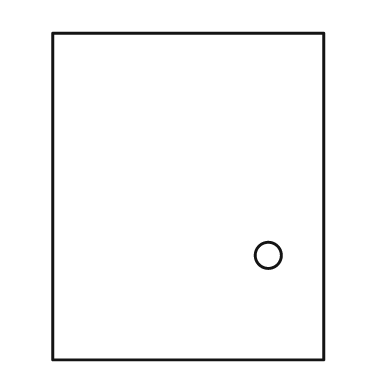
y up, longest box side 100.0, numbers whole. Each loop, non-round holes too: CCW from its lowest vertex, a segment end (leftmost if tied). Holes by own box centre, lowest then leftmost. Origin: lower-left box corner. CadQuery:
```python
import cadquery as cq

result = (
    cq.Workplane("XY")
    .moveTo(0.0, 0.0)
    .lineTo(83.0, 0.0)
    .lineTo(83.0, 100.0)
    .lineTo(0.0, 100.0)
    .close()
    .moveTo(66.0, 32.0)
    .circle(4.0)
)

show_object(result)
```